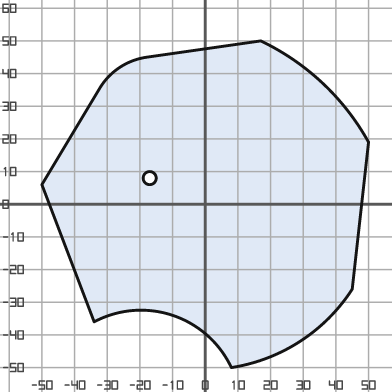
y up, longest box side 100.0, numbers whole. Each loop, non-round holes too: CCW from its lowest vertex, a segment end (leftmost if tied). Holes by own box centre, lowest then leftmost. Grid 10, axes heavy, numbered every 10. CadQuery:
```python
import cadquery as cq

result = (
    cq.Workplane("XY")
    .moveTo(8.0, -50.0)
    .threePointArc((29.0, -42.0), (45.0, -26.0))
    .lineTo(50.0, 19.0)
    .threePointArc((36.0, 37.0), (17.0, 50.0))
    .lineTo(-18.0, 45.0)
    .threePointArc((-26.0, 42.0), (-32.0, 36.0))
    .lineTo(-50.0, 6.0)
    .lineTo(-34.0, -36.0)
    .threePointArc((-10.0, -34.0), (8.0, -50.0))
    .close()
    .moveTo(-17.0, 8.0)
    .circle(2.0)
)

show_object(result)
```